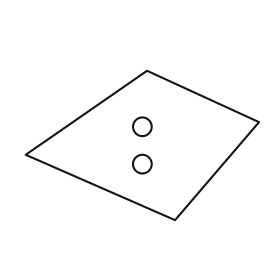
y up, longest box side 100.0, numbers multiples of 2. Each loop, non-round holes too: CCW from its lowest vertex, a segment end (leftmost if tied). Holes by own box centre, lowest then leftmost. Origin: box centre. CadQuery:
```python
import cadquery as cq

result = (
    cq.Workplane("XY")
    .moveTo(14.0, -32.0)
    .lineTo(50.0, 10.0)
    .lineTo(2.0, 32.0)
    .lineTo(-50.0, -4.0)
    .close()
    .moveTo(0.0, -8.0)
    .circle(4.0)
    .moveTo(0.0, 8.0)
    .circle(4.0)
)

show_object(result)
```